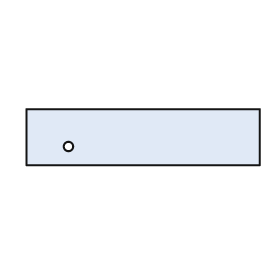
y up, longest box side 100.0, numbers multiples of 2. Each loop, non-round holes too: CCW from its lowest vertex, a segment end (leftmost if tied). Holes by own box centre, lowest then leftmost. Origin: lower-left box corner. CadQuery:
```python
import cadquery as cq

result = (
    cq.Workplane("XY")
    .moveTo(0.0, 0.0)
    .lineTo(100.0, 0.0)
    .lineTo(100.0, 24.0)
    .lineTo(0.0, 24.0)
    .close()
    .moveTo(18.0, 8.0)
    .circle(2.0)
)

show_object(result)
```